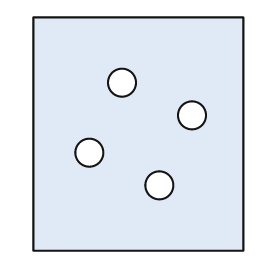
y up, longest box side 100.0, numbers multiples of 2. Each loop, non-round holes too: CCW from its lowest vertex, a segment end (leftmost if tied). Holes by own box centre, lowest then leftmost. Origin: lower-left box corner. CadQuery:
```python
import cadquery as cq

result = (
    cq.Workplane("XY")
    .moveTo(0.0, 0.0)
    .lineTo(90.0, 0.0)
    .lineTo(90.0, 100.0)
    .lineTo(0.0, 100.0)
    .close()
    .moveTo(54.0, 28.0)
    .circle(6.0)
    .moveTo(24.0, 42.0)
    .circle(6.0)
    .moveTo(68.0, 58.0)
    .circle(6.0)
    .moveTo(38.0, 72.0)
    .circle(6.0)
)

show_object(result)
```